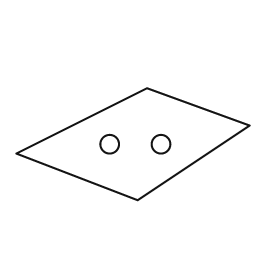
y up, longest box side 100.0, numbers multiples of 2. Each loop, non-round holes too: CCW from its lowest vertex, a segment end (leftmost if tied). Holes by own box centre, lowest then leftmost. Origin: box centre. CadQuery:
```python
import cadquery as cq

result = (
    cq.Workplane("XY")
    .moveTo(2.0, -24.0)
    .lineTo(50.0, 8.0)
    .lineTo(6.0, 24.0)
    .lineTo(-50.0, -4.0)
    .close()
    .moveTo(-10.0, 0.0)
    .circle(4.0)
    .moveTo(12.0, 0.0)
    .circle(4.0)
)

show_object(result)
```